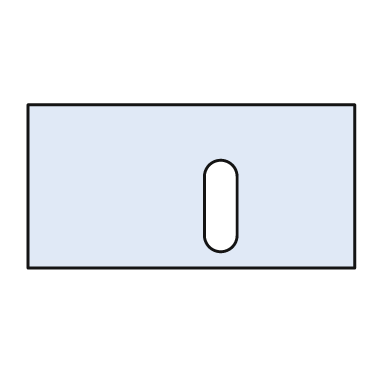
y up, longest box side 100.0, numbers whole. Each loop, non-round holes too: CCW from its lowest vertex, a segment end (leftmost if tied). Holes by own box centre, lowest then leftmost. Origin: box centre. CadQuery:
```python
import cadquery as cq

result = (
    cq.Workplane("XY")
    .moveTo(-50.0, -25.0)
    .lineTo(50.0, -25.0)
    .lineTo(50.0, 25.0)
    .lineTo(-50.0, 25.0)
    .close()
    .moveTo(4.0, -15.0)
    .threePointArc((9.0, -20.0), (14.0, -15.0))
    .lineTo(14.0, 3.0)
    .threePointArc((9.0, 8.0), (4.0, 3.0))
    .close()
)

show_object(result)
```